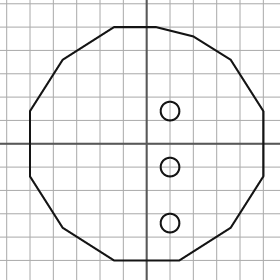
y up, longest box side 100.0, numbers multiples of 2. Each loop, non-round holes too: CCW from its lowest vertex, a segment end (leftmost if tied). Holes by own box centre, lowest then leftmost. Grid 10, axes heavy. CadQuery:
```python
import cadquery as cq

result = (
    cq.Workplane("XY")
    .moveTo(-14.0, -50.0)
    .lineTo(14.0, -50.0)
    .lineTo(36.0, -36.0)
    .lineTo(50.0, -14.0)
    .lineTo(50.0, 14.0)
    .lineTo(36.0, 36.0)
    .lineTo(20.0, 46.0)
    .lineTo(4.0, 50.0)
    .lineTo(-14.0, 50.0)
    .lineTo(-36.0, 36.0)
    .lineTo(-50.0, 14.0)
    .lineTo(-50.0, -14.0)
    .lineTo(-36.0, -36.0)
    .close()
    .moveTo(10.0, -34.0)
    .circle(4.0)
    .moveTo(10.0, -10.0)
    .circle(4.0)
    .moveTo(10.0, 14.0)
    .circle(4.0)
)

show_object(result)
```